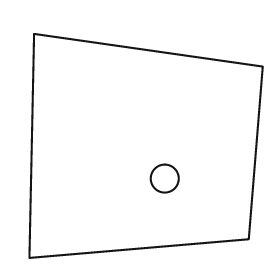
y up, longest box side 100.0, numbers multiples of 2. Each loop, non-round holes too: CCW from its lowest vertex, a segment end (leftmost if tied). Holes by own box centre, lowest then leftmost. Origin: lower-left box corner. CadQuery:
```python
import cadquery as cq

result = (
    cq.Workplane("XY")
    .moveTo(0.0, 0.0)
    .lineTo(94.0, 8.0)
    .lineTo(100.0, 82.0)
    .lineTo(2.0, 96.0)
    .close()
    .moveTo(58.0, 34.0)
    .circle(6.0)
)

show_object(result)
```